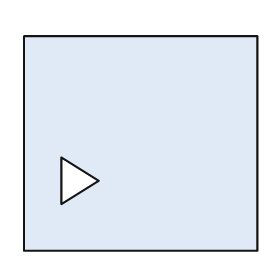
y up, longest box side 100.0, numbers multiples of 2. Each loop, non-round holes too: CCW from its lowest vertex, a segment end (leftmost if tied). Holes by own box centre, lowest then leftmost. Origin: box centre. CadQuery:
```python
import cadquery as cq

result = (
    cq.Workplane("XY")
    .moveTo(-50.0, -46.0)
    .lineTo(50.0, -46.0)
    .lineTo(50.0, 46.0)
    .lineTo(-50.0, 46.0)
    .close()
    .moveTo(-34.0, -26.0)
    .lineTo(-18.0, -16.0)
    .lineTo(-34.0, -6.0)
    .close()
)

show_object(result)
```